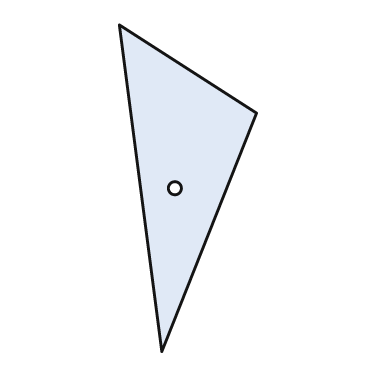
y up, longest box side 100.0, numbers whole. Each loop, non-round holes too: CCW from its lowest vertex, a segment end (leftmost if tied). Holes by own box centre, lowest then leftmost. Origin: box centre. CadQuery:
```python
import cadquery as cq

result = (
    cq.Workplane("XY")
    .moveTo(-8.0, -50.0)
    .lineTo(21.0, 23.0)
    .lineTo(-21.0, 50.0)
    .close()
    .moveTo(-4.0, 0.0)
    .circle(2.0)
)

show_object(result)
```